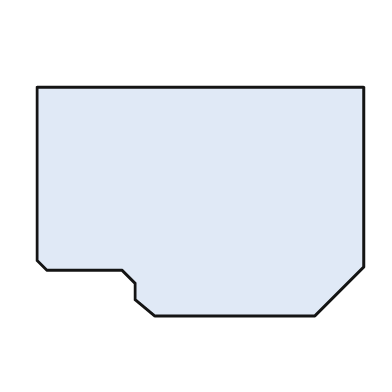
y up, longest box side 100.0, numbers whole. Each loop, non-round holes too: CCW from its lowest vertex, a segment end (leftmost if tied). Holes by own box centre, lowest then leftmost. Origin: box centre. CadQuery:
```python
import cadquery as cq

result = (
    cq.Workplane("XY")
    .moveTo(-14.0, -35.0)
    .lineTo(35.0, -35.0)
    .lineTo(50.0, -20.0)
    .lineTo(50.0, 35.0)
    .lineTo(-50.0, 35.0)
    .lineTo(-50.0, -18.0)
    .lineTo(-47.0, -21.0)
    .lineTo(-24.0, -21.0)
    .lineTo(-20.0, -25.0)
    .lineTo(-20.0, -30.0)
    .close()
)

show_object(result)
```